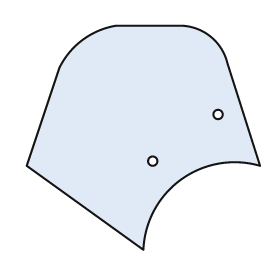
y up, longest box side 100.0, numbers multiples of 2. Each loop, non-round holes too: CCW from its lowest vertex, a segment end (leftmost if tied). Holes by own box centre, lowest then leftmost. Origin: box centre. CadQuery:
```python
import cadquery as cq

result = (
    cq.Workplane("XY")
    .moveTo(0.0, -48.0)
    .threePointArc((16.0, -18.0), (50.0, -12.0))
    .lineTo(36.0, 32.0)
    .threePointArc((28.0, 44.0), (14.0, 48.0))
    .lineTo(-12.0, 48.0)
    .threePointArc((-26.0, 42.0), (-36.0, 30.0))
    .lineTo(-50.0, -12.0)
    .close()
    .moveTo(4.0, -10.0)
    .circle(2.0)
    .moveTo(32.0, 10.0)
    .circle(2.0)
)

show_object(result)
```